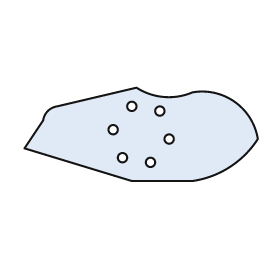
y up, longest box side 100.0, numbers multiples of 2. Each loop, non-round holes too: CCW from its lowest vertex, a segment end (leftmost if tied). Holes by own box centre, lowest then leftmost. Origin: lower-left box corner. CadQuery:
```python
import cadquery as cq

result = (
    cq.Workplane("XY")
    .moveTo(46.0, 0.0)
    .lineTo(72.0, 0.0)
    .threePointArc((88.0, 6.0), (100.0, 18.0))
    .threePointArc((90.0, 34.0), (72.0, 38.0))
    .threePointArc((60.0, 36.0), (48.0, 40.0))
    .lineTo(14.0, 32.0)
    .threePointArc((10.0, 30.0), (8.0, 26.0))
    .lineTo(0.0, 14.0)
    .close()
    .moveTo(54.0, 8.0)
    .circle(2.0)
    .moveTo(42.0, 10.0)
    .circle(2.0)
    .moveTo(62.0, 18.0)
    .circle(2.0)
    .moveTo(38.0, 22.0)
    .circle(2.0)
    .moveTo(58.0, 30.0)
    .circle(2.0)
    .moveTo(46.0, 32.0)
    .circle(2.0)
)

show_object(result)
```